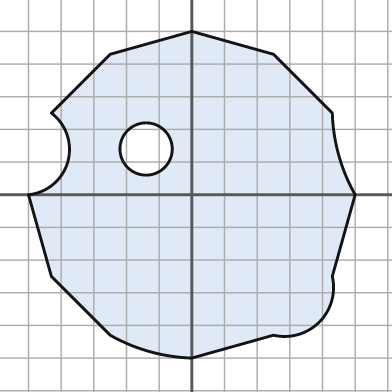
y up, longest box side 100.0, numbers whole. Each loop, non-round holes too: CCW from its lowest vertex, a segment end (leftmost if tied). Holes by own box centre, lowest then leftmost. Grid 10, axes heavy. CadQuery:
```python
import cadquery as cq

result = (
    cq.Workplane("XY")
    .moveTo(0.0, -50.0)
    .lineTo(25.0, -43.0)
    .threePointArc((39.0, -39.0), (43.0, -25.0))
    .lineTo(50.0, 0.0)
    .threePointArc((45.0, 12.0), (43.0, 25.0))
    .lineTo(25.0, 43.0)
    .lineTo(0.0, 50.0)
    .lineTo(-25.0, 43.0)
    .lineTo(-43.0, 25.0)
    .threePointArc((-38.0, 10.0), (-50.0, 0.0))
    .lineTo(-43.0, -25.0)
    .lineTo(-25.0, -43.0)
    .threePointArc((-13.0, -48.0), (0.0, -50.0))
    .close()
    .moveTo(-14.0, 14.0)
    .circle(8.0)
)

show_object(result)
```